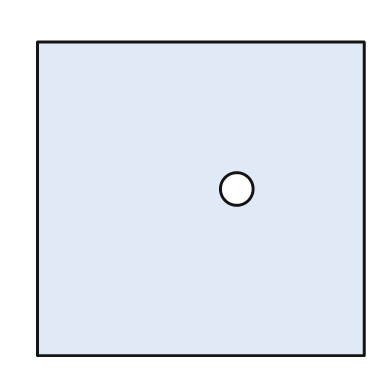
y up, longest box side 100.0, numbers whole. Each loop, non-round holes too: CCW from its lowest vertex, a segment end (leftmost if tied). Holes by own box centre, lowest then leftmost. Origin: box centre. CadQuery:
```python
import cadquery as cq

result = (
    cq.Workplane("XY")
    .moveTo(-50.0, -48.0)
    .lineTo(50.0, -48.0)
    .lineTo(50.0, 48.0)
    .lineTo(-50.0, 48.0)
    .close()
    .moveTo(11.0, 3.0)
    .circle(5.0)
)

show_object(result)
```